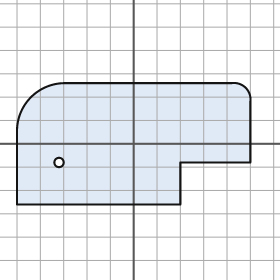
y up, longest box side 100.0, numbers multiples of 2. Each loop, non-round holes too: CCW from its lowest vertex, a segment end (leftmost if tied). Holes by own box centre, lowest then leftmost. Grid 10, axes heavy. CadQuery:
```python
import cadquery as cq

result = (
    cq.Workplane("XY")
    .moveTo(-50.0, -26.0)
    .lineTo(20.0, -26.0)
    .lineTo(20.0, -8.0)
    .lineTo(50.0, -8.0)
    .lineTo(50.0, 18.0)
    .threePointArc((48.0, 24.0), (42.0, 26.0))
    .lineTo(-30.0, 26.0)
    .threePointArc((-44.0, 20.0), (-50.0, 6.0))
    .close()
    .moveTo(-32.0, -8.0)
    .circle(2.0)
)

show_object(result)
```